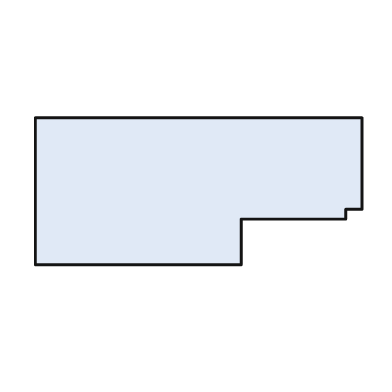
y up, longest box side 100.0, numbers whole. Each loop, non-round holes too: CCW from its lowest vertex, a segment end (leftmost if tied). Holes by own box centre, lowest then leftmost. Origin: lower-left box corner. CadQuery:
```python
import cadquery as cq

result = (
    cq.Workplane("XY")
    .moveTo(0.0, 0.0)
    .lineTo(63.0, 0.0)
    .lineTo(63.0, 14.0)
    .lineTo(95.0, 14.0)
    .lineTo(95.0, 17.0)
    .lineTo(100.0, 17.0)
    .lineTo(100.0, 45.0)
    .lineTo(0.0, 45.0)
    .close()
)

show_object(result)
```